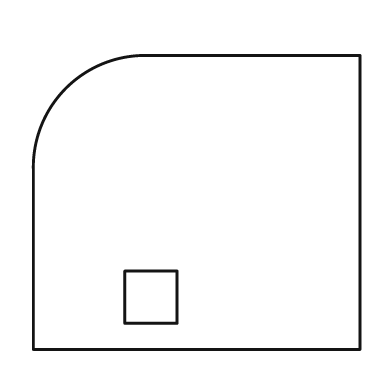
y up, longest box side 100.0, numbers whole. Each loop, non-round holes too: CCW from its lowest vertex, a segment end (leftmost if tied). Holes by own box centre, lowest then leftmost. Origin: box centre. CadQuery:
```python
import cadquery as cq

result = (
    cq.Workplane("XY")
    .moveTo(-50.0, -45.0)
    .lineTo(50.0, -45.0)
    .lineTo(50.0, 45.0)
    .lineTo(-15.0, 45.0)
    .threePointArc((-40.0, 35.0), (-50.0, 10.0))
    .close()
    .moveTo(-22.0, -37.0)
    .lineTo(-6.0, -37.0)
    .lineTo(-6.0, -21.0)
    .lineTo(-22.0, -21.0)
    .close()
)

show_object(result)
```